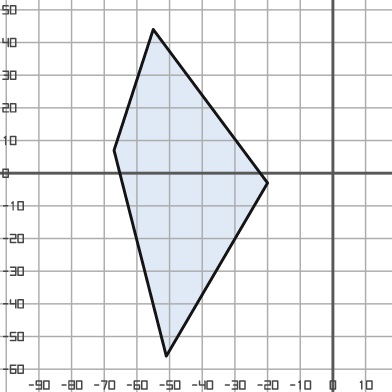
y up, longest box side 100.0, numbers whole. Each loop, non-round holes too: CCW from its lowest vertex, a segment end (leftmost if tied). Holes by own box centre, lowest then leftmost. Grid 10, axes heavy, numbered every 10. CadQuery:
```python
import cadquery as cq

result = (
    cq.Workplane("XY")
    .moveTo(-51.0, -56.0)
    .lineTo(-20.0, -3.0)
    .lineTo(-55.0, 44.0)
    .lineTo(-67.0, 7.0)
    .close()
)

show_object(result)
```